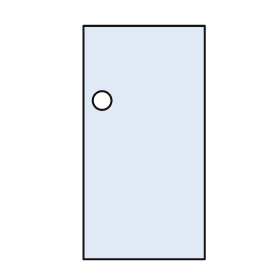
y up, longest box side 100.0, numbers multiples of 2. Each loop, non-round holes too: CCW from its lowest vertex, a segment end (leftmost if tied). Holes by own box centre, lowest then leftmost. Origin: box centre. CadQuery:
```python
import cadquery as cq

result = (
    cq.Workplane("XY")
    .moveTo(-26.0, -50.0)
    .lineTo(26.0, -50.0)
    .lineTo(26.0, 50.0)
    .lineTo(-26.0, 50.0)
    .close()
    .moveTo(-18.0, 18.0)
    .circle(4.0)
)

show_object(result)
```